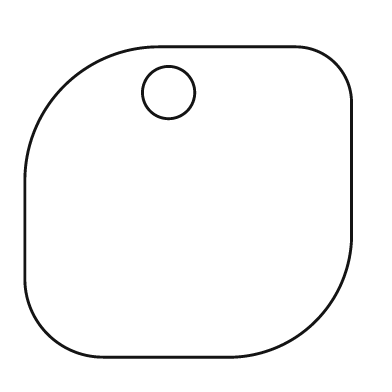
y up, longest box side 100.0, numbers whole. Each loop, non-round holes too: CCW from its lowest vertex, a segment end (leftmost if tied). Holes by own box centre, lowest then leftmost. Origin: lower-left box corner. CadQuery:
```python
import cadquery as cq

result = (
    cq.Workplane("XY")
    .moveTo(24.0, 0.0)
    .lineTo(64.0, 0.0)
    .threePointArc((89.0, 11.0), (100.0, 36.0))
    .lineTo(100.0, 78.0)
    .threePointArc((95.0, 90.0), (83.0, 95.0))
    .lineTo(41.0, 95.0)
    .threePointArc((12.0, 83.0), (0.0, 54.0))
    .lineTo(0.0, 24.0)
    .threePointArc((7.0, 7.0), (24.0, 0.0))
    .close()
    .moveTo(44.0, 81.0)
    .circle(8.0)
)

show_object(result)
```